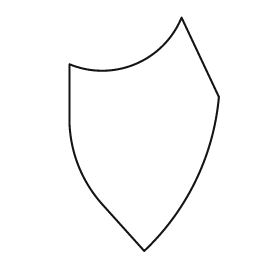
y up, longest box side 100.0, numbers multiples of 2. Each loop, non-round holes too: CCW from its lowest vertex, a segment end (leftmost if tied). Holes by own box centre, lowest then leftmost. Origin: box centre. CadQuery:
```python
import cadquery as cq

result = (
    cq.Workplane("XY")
    .moveTo(0.0, -50.0)
    .threePointArc((22.0, -20.0), (32.0, 16.0))
    .lineTo(16.0, 50.0)
    .threePointArc((-4.0, 30.0), (-32.0, 30.0))
    .lineTo(-32.0, 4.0)
    .threePointArc((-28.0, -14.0), (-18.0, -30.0))
    .close()
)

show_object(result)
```